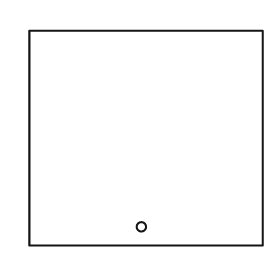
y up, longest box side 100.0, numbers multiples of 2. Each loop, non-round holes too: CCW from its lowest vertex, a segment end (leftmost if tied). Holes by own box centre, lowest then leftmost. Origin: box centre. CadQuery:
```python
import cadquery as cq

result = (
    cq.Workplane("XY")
    .moveTo(-50.0, -46.0)
    .lineTo(50.0, -46.0)
    .lineTo(50.0, 46.0)
    .lineTo(-50.0, 46.0)
    .close()
    .moveTo(-2.0, -38.0)
    .circle(2.0)
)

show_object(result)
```